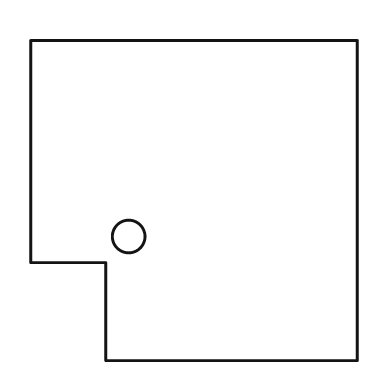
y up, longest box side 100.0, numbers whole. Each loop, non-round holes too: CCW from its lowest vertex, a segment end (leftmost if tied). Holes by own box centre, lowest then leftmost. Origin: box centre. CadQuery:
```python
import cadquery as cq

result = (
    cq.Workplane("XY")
    .moveTo(-27.0, -49.0)
    .lineTo(50.0, -49.0)
    .lineTo(50.0, 49.0)
    .lineTo(-50.0, 49.0)
    .lineTo(-50.0, -19.0)
    .lineTo(-27.0, -19.0)
    .close()
    .moveTo(-20.0, -11.0)
    .circle(5.0)
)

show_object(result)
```